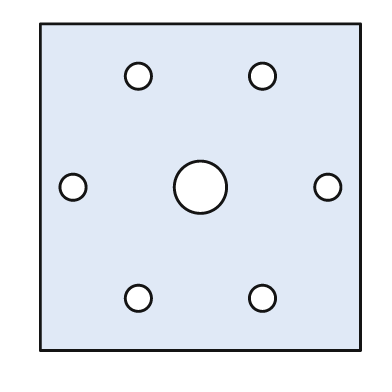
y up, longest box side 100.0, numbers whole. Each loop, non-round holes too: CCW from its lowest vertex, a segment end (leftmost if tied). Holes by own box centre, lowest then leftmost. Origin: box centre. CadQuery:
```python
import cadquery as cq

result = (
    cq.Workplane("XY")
    .moveTo(-49.0, -50.0)
    .lineTo(49.0, -50.0)
    .lineTo(49.0, 50.0)
    .lineTo(-49.0, 50.0)
    .close()
    .moveTo(-19.0, -34.0)
    .circle(4.0)
    .moveTo(19.0, -34.0)
    .circle(4.0)
    .moveTo(-39.0, 0.0)
    .circle(4.0)
    .moveTo(0.0, 0.0)
    .circle(8.0)
    .moveTo(39.0, 0.0)
    .circle(4.0)
    .moveTo(-19.0, 34.0)
    .circle(4.0)
    .moveTo(19.0, 34.0)
    .circle(4.0)
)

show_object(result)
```